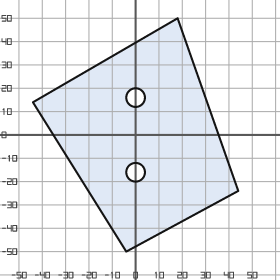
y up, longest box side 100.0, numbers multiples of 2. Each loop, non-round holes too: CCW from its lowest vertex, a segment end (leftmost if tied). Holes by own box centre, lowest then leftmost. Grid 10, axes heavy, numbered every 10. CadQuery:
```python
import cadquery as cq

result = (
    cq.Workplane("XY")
    .moveTo(-4.0, -50.0)
    .lineTo(44.0, -24.0)
    .lineTo(18.0, 50.0)
    .lineTo(-44.0, 14.0)
    .close()
    .moveTo(0.0, -16.0)
    .circle(4.0)
    .moveTo(0.0, 16.0)
    .circle(4.0)
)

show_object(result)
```